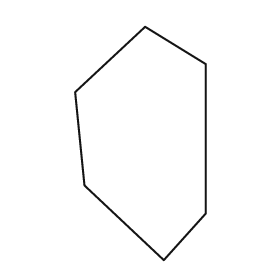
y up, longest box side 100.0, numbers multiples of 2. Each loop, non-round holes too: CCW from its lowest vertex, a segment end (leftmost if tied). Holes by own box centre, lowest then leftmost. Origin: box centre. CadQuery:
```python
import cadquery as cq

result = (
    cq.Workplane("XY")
    .moveTo(10.0, -50.0)
    .lineTo(28.0, -30.0)
    .lineTo(28.0, 34.0)
    .lineTo(2.0, 50.0)
    .lineTo(-28.0, 22.0)
    .lineTo(-24.0, -18.0)
    .close()
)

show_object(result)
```